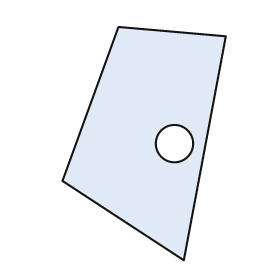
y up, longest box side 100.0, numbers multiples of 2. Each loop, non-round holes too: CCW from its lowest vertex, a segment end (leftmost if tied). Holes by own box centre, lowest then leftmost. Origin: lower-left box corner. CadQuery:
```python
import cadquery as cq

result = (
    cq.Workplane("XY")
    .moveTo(52.0, 0.0)
    .lineTo(70.0, 96.0)
    .lineTo(24.0, 100.0)
    .lineTo(0.0, 34.0)
    .close()
    .moveTo(48.0, 50.0)
    .circle(8.0)
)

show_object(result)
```